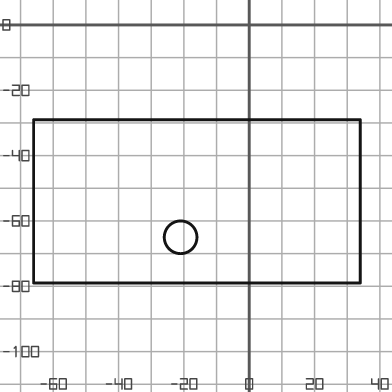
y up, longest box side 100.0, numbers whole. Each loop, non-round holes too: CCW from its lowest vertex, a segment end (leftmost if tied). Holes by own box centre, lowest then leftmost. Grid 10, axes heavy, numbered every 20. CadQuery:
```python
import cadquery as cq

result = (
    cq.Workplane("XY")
    .moveTo(-66.0, -79.0)
    .lineTo(34.0, -79.0)
    .lineTo(34.0, -29.0)
    .lineTo(-66.0, -29.0)
    .close()
    .moveTo(-21.0, -65.0)
    .circle(5.0)
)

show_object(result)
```